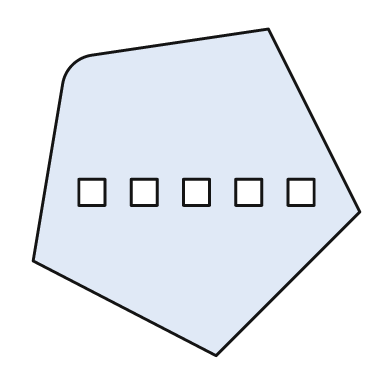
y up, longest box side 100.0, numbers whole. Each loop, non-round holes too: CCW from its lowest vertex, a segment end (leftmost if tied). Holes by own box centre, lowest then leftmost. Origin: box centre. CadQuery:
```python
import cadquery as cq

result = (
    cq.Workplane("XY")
    .moveTo(6.0, -50.0)
    .lineTo(50.0, -6.0)
    .lineTo(22.0, 50.0)
    .lineTo(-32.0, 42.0)
    .threePointArc((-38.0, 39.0), (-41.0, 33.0))
    .lineTo(-50.0, -21.0)
    .close()
    .moveTo(-36.0, -4.0)
    .lineTo(-28.0, -4.0)
    .lineTo(-28.0, 4.0)
    .lineTo(-36.0, 4.0)
    .close()
    .moveTo(-20.0, -4.0)
    .lineTo(-12.0, -4.0)
    .lineTo(-12.0, 4.0)
    .lineTo(-20.0, 4.0)
    .close()
    .moveTo(-4.0, -4.0)
    .lineTo(4.0, -4.0)
    .lineTo(4.0, 4.0)
    .lineTo(-4.0, 4.0)
    .close()
    .moveTo(12.0, -4.0)
    .lineTo(20.0, -4.0)
    .lineTo(20.0, 4.0)
    .lineTo(12.0, 4.0)
    .close()
    .moveTo(28.0, -4.0)
    .lineTo(36.0, -4.0)
    .lineTo(36.0, 4.0)
    .lineTo(28.0, 4.0)
    .close()
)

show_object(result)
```